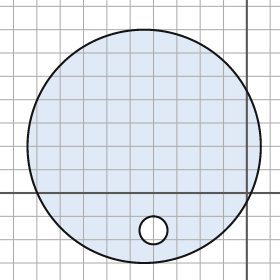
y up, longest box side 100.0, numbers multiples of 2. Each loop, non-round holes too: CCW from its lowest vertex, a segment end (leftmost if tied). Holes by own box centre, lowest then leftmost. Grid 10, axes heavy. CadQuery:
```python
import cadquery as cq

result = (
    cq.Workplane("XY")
    .moveTo(-44.0, 20.0)
    .circle(50.0)
    .moveTo(-40.0, -16.0)
    .circle(6.0)
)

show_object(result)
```